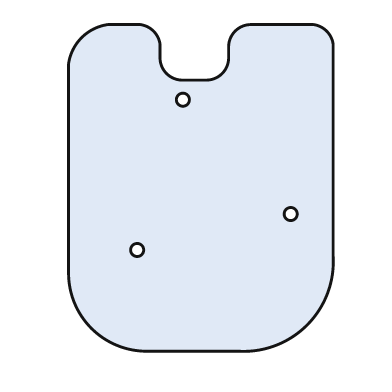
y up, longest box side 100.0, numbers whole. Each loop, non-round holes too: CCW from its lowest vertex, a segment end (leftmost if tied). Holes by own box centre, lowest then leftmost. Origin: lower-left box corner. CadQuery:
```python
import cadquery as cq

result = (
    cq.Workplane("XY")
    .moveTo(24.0, 0.0)
    .lineTo(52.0, 0.0)
    .threePointArc((73.0, 8.0), (81.0, 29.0))
    .lineTo(81.0, 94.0)
    .threePointArc((79.0, 98.0), (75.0, 100.0))
    .lineTo(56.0, 100.0)
    .threePointArc((51.0, 98.0), (49.0, 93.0))
    .lineTo(49.0, 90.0)
    .threePointArc((47.0, 85.0), (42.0, 83.0))
    .lineTo(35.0, 83.0)
    .threePointArc((30.0, 85.0), (28.0, 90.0))
    .lineTo(28.0, 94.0)
    .threePointArc((26.0, 98.0), (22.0, 100.0))
    .lineTo(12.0, 100.0)
    .threePointArc((4.0, 96.0), (0.0, 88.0))
    .lineTo(0.0, 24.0)
    .threePointArc((7.0, 7.0), (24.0, 0.0))
    .close()
    .moveTo(21.0, 31.0)
    .circle(2.0)
    .moveTo(68.0, 42.0)
    .circle(2.0)
    .moveTo(35.0, 77.0)
    .circle(2.0)
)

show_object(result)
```